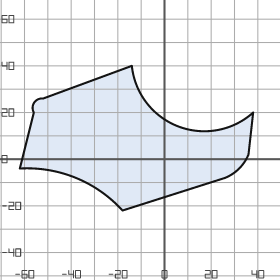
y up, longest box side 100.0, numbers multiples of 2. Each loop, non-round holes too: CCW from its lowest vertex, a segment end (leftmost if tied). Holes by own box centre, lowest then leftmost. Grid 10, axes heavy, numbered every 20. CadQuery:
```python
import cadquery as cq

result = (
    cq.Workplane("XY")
    .moveTo(-18.0, -22.0)
    .lineTo(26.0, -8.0)
    .threePointArc((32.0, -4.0), (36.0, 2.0))
    .lineTo(38.0, 20.0)
    .threePointArc((6.0, 14.0), (-14.0, 40.0))
    .lineTo(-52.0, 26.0)
    .threePointArc((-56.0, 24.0), (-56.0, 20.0))
    .lineTo(-62.0, -4.0)
    .threePointArc((-38.0, -8.0), (-18.0, -22.0))
    .close()
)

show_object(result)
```